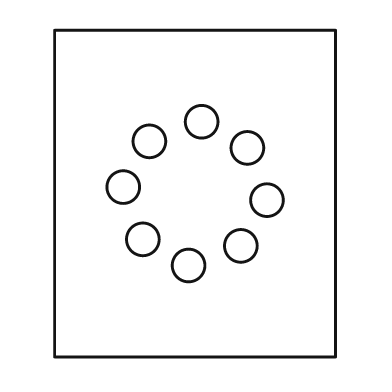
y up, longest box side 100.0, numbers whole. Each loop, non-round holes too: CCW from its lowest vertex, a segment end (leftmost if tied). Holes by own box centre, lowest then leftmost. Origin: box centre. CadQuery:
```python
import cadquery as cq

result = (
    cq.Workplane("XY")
    .moveTo(-43.0, -50.0)
    .lineTo(43.0, -50.0)
    .lineTo(43.0, 50.0)
    .lineTo(-43.0, 50.0)
    .close()
    .moveTo(-2.0, -22.0)
    .circle(5.0)
    .moveTo(14.0, -16.0)
    .circle(5.0)
    .moveTo(-16.0, -14.0)
    .circle(5.0)
    .moveTo(22.0, -2.0)
    .circle(5.0)
    .moveTo(-22.0, 2.0)
    .circle(5.0)
    .moveTo(16.0, 14.0)
    .circle(5.0)
    .moveTo(-14.0, 16.0)
    .circle(5.0)
    .moveTo(2.0, 22.0)
    .circle(5.0)
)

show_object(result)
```